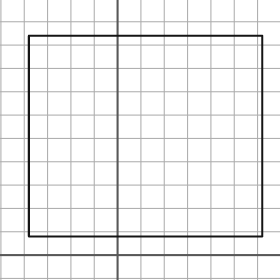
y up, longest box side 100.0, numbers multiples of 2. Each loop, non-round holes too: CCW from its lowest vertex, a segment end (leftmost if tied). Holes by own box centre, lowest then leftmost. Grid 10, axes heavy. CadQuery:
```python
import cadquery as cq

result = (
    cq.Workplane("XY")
    .moveTo(-38.0, 8.0)
    .lineTo(62.0, 8.0)
    .lineTo(62.0, 94.0)
    .lineTo(-38.0, 94.0)
    .close()
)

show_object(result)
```